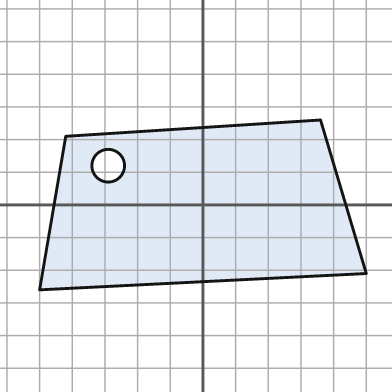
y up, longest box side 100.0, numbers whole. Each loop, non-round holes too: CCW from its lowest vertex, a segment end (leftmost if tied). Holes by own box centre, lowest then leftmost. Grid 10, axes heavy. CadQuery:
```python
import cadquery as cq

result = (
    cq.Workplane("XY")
    .moveTo(-50.0, -26.0)
    .lineTo(50.0, -21.0)
    .lineTo(36.0, 26.0)
    .lineTo(-42.0, 21.0)
    .close()
    .moveTo(-29.0, 12.0)
    .circle(5.0)
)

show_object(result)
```